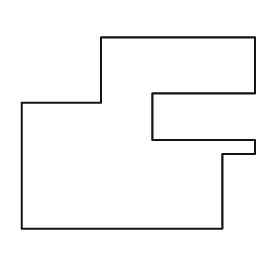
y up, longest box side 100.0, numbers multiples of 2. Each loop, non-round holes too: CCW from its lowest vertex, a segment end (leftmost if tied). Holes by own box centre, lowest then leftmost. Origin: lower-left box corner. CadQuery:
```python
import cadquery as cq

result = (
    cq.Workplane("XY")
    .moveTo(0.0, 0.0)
    .lineTo(86.0, 0.0)
    .lineTo(86.0, 32.0)
    .lineTo(100.0, 32.0)
    .lineTo(100.0, 38.0)
    .lineTo(56.0, 38.0)
    .lineTo(56.0, 58.0)
    .lineTo(100.0, 58.0)
    .lineTo(100.0, 82.0)
    .lineTo(34.0, 82.0)
    .lineTo(34.0, 54.0)
    .lineTo(0.0, 54.0)
    .close()
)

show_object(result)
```